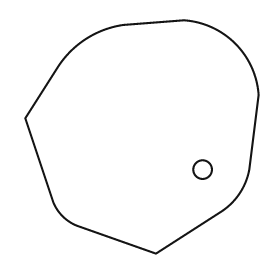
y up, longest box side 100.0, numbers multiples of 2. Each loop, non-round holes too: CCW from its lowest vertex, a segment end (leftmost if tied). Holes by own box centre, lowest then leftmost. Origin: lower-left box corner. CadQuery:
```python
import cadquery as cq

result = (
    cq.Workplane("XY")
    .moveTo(56.0, 0.0)
    .lineTo(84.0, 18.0)
    .threePointArc((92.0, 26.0), (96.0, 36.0))
    .lineTo(100.0, 68.0)
    .threePointArc((90.0, 90.0), (68.0, 100.0))
    .lineTo(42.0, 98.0)
    .threePointArc((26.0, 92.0), (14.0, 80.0))
    .lineTo(0.0, 58.0)
    .lineTo(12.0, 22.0)
    .threePointArc((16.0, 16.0), (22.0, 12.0))
    .close()
    .moveTo(76.0, 36.0)
    .circle(4.0)
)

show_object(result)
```